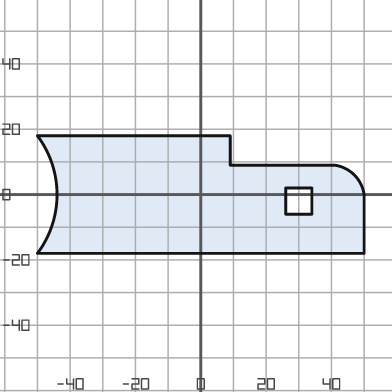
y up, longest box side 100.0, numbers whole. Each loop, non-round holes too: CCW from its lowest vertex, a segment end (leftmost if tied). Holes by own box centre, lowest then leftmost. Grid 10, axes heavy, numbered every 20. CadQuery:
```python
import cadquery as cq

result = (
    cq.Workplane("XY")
    .moveTo(-50.0, -18.0)
    .lineTo(50.0, -18.0)
    .lineTo(50.0, 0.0)
    .threePointArc((47.0, 6.0), (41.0, 9.0))
    .lineTo(9.0, 9.0)
    .lineTo(9.0, 18.0)
    .lineTo(-50.0, 18.0)
    .threePointArc((-44.0, 0.0), (-50.0, -18.0))
    .close()
    .moveTo(26.0, -6.0)
    .lineTo(34.0, -6.0)
    .lineTo(34.0, 2.0)
    .lineTo(26.0, 2.0)
    .close()
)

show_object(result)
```